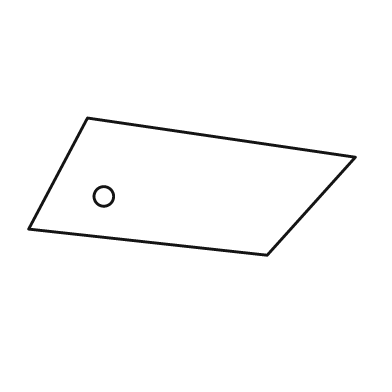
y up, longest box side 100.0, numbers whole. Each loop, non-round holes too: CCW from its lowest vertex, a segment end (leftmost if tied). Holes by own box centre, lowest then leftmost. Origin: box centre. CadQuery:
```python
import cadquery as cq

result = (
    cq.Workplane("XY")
    .moveTo(23.0, -21.0)
    .lineTo(50.0, 9.0)
    .lineTo(-32.0, 21.0)
    .lineTo(-50.0, -13.0)
    .close()
    .moveTo(-27.0, -3.0)
    .circle(3.0)
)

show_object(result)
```